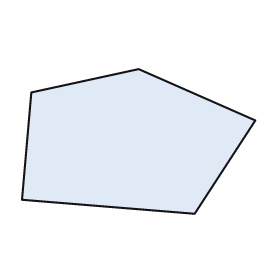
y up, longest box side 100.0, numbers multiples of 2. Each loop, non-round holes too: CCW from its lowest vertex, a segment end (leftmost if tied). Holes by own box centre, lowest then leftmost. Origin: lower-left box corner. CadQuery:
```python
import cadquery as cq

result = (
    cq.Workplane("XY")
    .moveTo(74.0, 0.0)
    .lineTo(100.0, 40.0)
    .lineTo(50.0, 62.0)
    .lineTo(4.0, 52.0)
    .lineTo(0.0, 6.0)
    .close()
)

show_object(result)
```